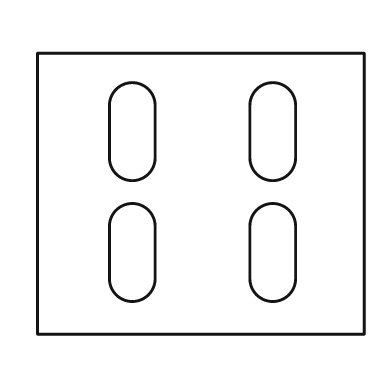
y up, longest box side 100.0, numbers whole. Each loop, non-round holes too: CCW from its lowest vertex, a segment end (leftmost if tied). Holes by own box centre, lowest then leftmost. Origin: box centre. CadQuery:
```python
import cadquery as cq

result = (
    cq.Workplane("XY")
    .moveTo(-50.0, -43.0)
    .lineTo(50.0, -43.0)
    .lineTo(50.0, 43.0)
    .lineTo(-50.0, 43.0)
    .close()
    .moveTo(-28.0, -26.0)
    .threePointArc((-21.0, -33.0), (-14.0, -26.0))
    .lineTo(-14.0, -10.0)
    .threePointArc((-21.0, -3.0), (-28.0, -10.0))
    .close()
    .moveTo(15.0, -26.0)
    .threePointArc((22.0, -33.0), (29.0, -26.0))
    .lineTo(29.0, -10.0)
    .threePointArc((22.0, -3.0), (15.0, -10.0))
    .close()
    .moveTo(-28.0, 11.0)
    .threePointArc((-21.0, 4.0), (-14.0, 11.0))
    .lineTo(-14.0, 27.0)
    .threePointArc((-21.0, 34.0), (-28.0, 27.0))
    .close()
    .moveTo(15.0, 11.0)
    .threePointArc((22.0, 4.0), (29.0, 11.0))
    .lineTo(29.0, 27.0)
    .threePointArc((22.0, 34.0), (15.0, 27.0))
    .close()
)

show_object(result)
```